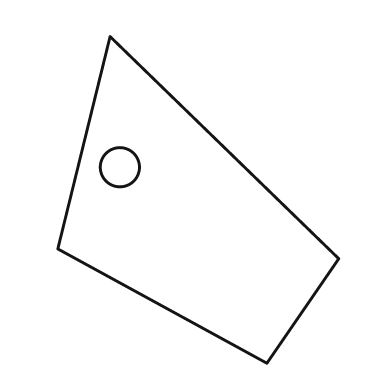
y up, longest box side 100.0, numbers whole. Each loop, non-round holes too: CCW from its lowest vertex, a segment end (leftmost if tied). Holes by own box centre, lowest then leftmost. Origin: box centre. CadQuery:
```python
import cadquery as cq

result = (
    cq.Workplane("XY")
    .moveTo(21.0, -50.0)
    .lineTo(43.0, -18.0)
    .lineTo(-27.0, 50.0)
    .lineTo(-43.0, -15.0)
    .close()
    .moveTo(-24.0, 10.0)
    .circle(6.0)
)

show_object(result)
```